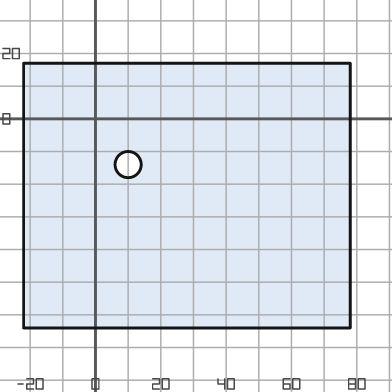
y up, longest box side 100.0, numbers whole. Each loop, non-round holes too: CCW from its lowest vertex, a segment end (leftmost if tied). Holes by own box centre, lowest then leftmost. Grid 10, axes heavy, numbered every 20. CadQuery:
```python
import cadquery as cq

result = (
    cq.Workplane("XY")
    .moveTo(-22.0, -64.0)
    .lineTo(78.0, -64.0)
    .lineTo(78.0, 17.0)
    .lineTo(-22.0, 17.0)
    .close()
    .moveTo(10.0, -14.0)
    .circle(4.0)
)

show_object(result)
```